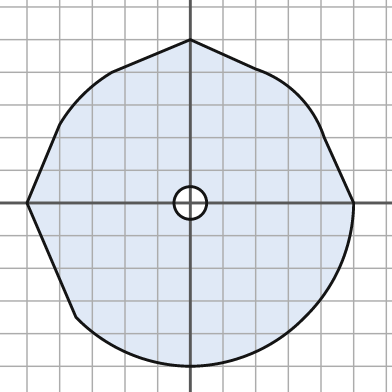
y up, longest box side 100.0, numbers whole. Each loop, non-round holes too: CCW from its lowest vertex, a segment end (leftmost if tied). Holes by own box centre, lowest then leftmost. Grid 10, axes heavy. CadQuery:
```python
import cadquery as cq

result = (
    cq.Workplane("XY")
    .moveTo(0.0, -50.0)
    .threePointArc((19.0, -46.0), (35.0, -35.0))
    .threePointArc((46.0, -19.0), (50.0, 0.0))
    .lineTo(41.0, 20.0)
    .threePointArc((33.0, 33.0), (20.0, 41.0))
    .lineTo(0.0, 50.0)
    .lineTo(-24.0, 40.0)
    .threePointArc((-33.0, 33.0), (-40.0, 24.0))
    .lineTo(-50.0, 0.0)
    .lineTo(-35.0, -35.0)
    .threePointArc((-19.0, -46.0), (0.0, -50.0))
    .close()
    .moveTo(0.0, 0.0)
    .circle(5.0)
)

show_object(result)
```